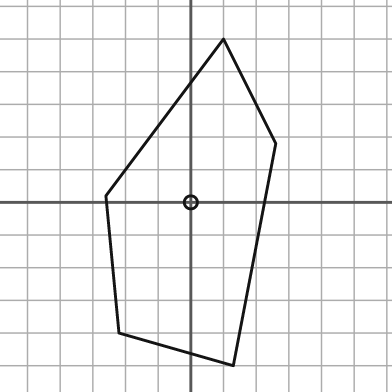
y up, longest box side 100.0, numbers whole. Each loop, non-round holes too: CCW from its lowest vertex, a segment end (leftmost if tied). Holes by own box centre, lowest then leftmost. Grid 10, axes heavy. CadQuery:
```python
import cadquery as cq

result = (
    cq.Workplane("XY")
    .moveTo(13.0, -50.0)
    .lineTo(26.0, 18.0)
    .lineTo(10.0, 50.0)
    .lineTo(-26.0, 2.0)
    .lineTo(-22.0, -40.0)
    .close()
    .moveTo(0.0, 0.0)
    .circle(2.0)
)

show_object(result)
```